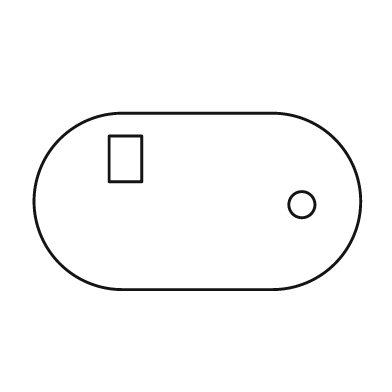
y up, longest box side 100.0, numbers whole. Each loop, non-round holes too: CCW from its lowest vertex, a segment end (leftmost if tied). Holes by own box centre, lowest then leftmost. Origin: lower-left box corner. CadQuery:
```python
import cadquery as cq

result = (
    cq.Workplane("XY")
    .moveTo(27.0, 0.0)
    .lineTo(73.0, 0.0)
    .threePointArc((100.0, 27.0), (73.0, 54.0))
    .lineTo(27.0, 54.0)
    .threePointArc((0.0, 27.0), (27.0, 0.0))
    .close()
    .moveTo(82.0, 26.0)
    .circle(4.0)
    .moveTo(23.0, 33.0)
    .lineTo(33.0, 33.0)
    .lineTo(33.0, 47.0)
    .lineTo(23.0, 47.0)
    .close()
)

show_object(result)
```